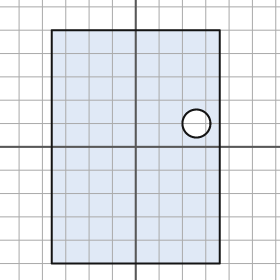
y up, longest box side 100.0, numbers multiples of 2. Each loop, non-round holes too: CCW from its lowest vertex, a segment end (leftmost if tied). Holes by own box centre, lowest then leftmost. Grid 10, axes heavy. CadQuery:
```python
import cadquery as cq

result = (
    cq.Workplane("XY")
    .moveTo(-36.0, -50.0)
    .lineTo(36.0, -50.0)
    .lineTo(36.0, 50.0)
    .lineTo(-36.0, 50.0)
    .close()
    .moveTo(26.0, 10.0)
    .circle(6.0)
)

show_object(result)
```